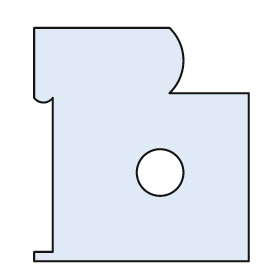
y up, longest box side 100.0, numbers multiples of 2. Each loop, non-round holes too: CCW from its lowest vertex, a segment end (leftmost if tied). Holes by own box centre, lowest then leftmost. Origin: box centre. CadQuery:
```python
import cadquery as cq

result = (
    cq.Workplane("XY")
    .moveTo(-46.0, -50.0)
    .lineTo(46.0, -50.0)
    .lineTo(46.0, 22.0)
    .lineTo(12.0, 22.0)
    .threePointArc((18.0, 36.0), (12.0, 50.0))
    .lineTo(-46.0, 50.0)
    .lineTo(-46.0, 20.0)
    .threePointArc((-42.0, 18.0), (-38.0, 20.0))
    .lineTo(-38.0, -46.0)
    .lineTo(-46.0, -46.0)
    .close()
    .moveTo(8.0, -12.0)
    .circle(10.0)
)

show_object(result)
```